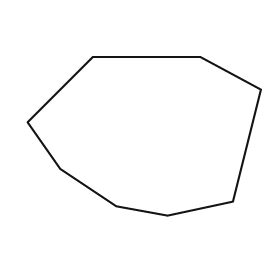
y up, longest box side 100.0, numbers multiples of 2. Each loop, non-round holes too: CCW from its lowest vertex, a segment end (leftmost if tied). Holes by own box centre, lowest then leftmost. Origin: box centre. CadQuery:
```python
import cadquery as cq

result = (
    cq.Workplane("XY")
    .moveTo(10.0, -34.0)
    .lineTo(38.0, -28.0)
    .lineTo(50.0, 20.0)
    .lineTo(24.0, 34.0)
    .lineTo(-22.0, 34.0)
    .lineTo(-50.0, 6.0)
    .lineTo(-36.0, -14.0)
    .lineTo(-12.0, -30.0)
    .close()
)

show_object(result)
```